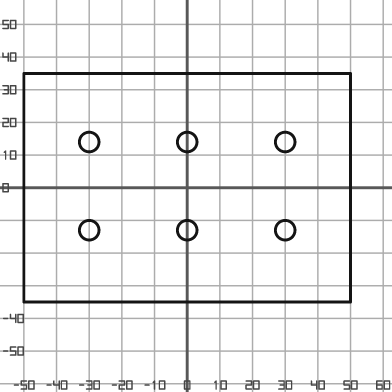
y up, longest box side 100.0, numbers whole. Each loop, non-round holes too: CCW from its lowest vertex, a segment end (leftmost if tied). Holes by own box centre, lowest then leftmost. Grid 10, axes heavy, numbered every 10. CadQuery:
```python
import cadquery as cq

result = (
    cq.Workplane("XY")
    .moveTo(-50.0, -35.0)
    .lineTo(50.0, -35.0)
    .lineTo(50.0, 35.0)
    .lineTo(-50.0, 35.0)
    .close()
    .moveTo(-30.0, -13.0)
    .circle(3.0)
    .moveTo(0.0, -13.0)
    .circle(3.0)
    .moveTo(30.0, -13.0)
    .circle(3.0)
    .moveTo(-30.0, 14.0)
    .circle(3.0)
    .moveTo(0.0, 14.0)
    .circle(3.0)
    .moveTo(30.0, 14.0)
    .circle(3.0)
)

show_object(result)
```